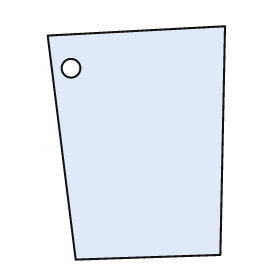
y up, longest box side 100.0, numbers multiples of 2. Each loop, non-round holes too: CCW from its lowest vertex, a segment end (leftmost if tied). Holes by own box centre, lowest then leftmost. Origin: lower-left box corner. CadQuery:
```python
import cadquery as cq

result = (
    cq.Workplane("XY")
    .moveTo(12.0, 0.0)
    .lineTo(74.0, 2.0)
    .lineTo(76.0, 100.0)
    .lineTo(0.0, 96.0)
    .close()
    .moveTo(10.0, 82.0)
    .circle(4.0)
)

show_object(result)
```